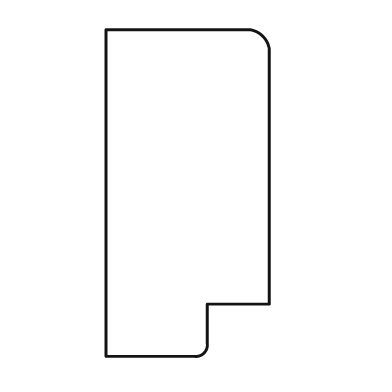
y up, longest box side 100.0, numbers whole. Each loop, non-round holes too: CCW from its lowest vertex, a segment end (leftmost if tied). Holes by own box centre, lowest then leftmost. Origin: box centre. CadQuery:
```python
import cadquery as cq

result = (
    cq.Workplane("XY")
    .moveTo(-25.0, -50.0)
    .lineTo(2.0, -50.0)
    .threePointArc((5.0, -49.0), (6.0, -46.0))
    .lineTo(6.0, -34.0)
    .lineTo(25.0, -34.0)
    .lineTo(25.0, 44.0)
    .threePointArc((23.0, 48.0), (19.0, 50.0))
    .lineTo(-25.0, 50.0)
    .close()
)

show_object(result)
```